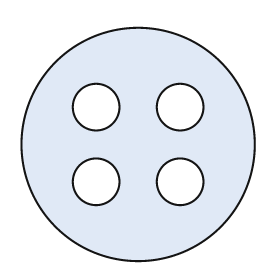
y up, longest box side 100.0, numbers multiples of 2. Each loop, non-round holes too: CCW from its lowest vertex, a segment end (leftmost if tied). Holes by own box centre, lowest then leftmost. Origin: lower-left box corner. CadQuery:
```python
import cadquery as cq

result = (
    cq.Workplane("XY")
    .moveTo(50.0, 50.0)
    .circle(50.0)
    .moveTo(32.0, 34.0)
    .circle(10.0)
    .moveTo(68.0, 34.0)
    .circle(10.0)
    .moveTo(32.0, 66.0)
    .circle(10.0)
    .moveTo(68.0, 66.0)
    .circle(10.0)
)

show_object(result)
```